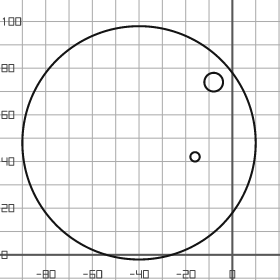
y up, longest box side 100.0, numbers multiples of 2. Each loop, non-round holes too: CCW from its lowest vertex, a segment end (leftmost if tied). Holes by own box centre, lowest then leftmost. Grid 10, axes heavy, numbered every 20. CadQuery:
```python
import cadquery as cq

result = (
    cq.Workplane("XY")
    .moveTo(-40.0, 48.0)
    .circle(50.0)
    .moveTo(-16.0, 42.0)
    .circle(2.0)
    .moveTo(-8.0, 74.0)
    .circle(4.0)
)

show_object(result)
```